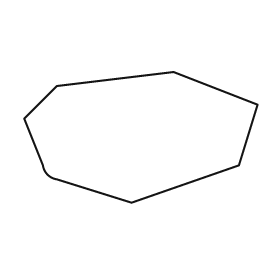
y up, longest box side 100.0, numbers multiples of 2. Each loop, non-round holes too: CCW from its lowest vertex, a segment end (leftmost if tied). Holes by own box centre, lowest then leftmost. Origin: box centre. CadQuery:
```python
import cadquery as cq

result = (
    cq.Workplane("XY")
    .moveTo(-4.0, -28.0)
    .lineTo(42.0, -12.0)
    .lineTo(50.0, 14.0)
    .lineTo(14.0, 28.0)
    .lineTo(-36.0, 22.0)
    .lineTo(-50.0, 8.0)
    .lineTo(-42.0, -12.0)
    .threePointArc((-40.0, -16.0), (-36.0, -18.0))
    .close()
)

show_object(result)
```